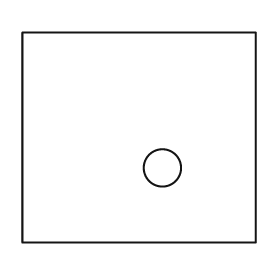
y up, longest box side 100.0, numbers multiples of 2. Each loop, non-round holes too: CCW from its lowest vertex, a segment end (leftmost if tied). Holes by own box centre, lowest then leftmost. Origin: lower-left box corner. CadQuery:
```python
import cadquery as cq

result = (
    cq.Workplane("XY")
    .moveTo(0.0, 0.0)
    .lineTo(100.0, 0.0)
    .lineTo(100.0, 90.0)
    .lineTo(0.0, 90.0)
    .close()
    .moveTo(60.0, 32.0)
    .circle(8.0)
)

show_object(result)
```